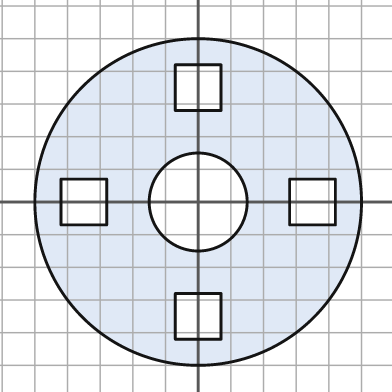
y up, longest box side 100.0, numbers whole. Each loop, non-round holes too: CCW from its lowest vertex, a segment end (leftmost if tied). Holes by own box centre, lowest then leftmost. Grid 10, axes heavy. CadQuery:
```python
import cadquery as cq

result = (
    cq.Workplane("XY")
    .moveTo(0.0, 0.0)
    .circle(50.0)
    .moveTo(-7.0, -42.0)
    .lineTo(7.0, -42.0)
    .lineTo(7.0, -28.0)
    .lineTo(-7.0, -28.0)
    .close()
    .moveTo(-42.0, -7.0)
    .lineTo(-28.0, -7.0)
    .lineTo(-28.0, 7.0)
    .lineTo(-42.0, 7.0)
    .close()
    .moveTo(0.0, 0.0)
    .circle(15.0)
    .moveTo(28.0, -7.0)
    .lineTo(42.0, -7.0)
    .lineTo(42.0, 7.0)
    .lineTo(28.0, 7.0)
    .close()
    .moveTo(-7.0, 28.0)
    .lineTo(7.0, 28.0)
    .lineTo(7.0, 42.0)
    .lineTo(-7.0, 42.0)
    .close()
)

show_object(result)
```